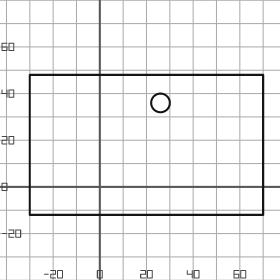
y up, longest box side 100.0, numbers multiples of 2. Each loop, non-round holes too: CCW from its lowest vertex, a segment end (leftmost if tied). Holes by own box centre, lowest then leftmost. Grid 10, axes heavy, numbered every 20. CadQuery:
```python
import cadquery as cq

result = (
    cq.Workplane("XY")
    .moveTo(-30.0, -12.0)
    .lineTo(70.0, -12.0)
    .lineTo(70.0, 48.0)
    .lineTo(-30.0, 48.0)
    .close()
    .moveTo(26.0, 36.0)
    .circle(4.0)
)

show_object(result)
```